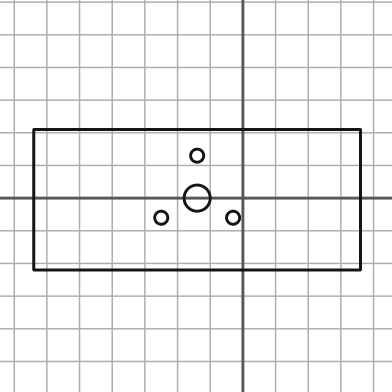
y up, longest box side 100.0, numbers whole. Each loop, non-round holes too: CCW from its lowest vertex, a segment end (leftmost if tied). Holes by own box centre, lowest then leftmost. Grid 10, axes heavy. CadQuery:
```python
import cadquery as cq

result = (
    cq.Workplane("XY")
    .moveTo(-64.0, -22.0)
    .lineTo(36.0, -22.0)
    .lineTo(36.0, 21.0)
    .lineTo(-64.0, 21.0)
    .close()
    .moveTo(-25.0, -6.0)
    .circle(2.0)
    .moveTo(-3.0, -6.0)
    .circle(2.0)
    .moveTo(-14.0, 0.0)
    .circle(4.0)
    .moveTo(-14.0, 13.0)
    .circle(2.0)
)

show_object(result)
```